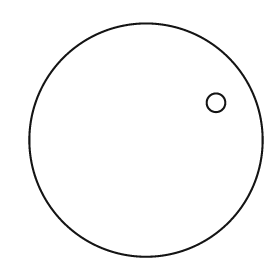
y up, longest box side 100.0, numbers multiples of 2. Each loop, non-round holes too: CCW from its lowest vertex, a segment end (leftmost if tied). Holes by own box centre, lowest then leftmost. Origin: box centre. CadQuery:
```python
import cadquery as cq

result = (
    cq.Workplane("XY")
    .moveTo(0.0, 0.0)
    .circle(50.0)
    .moveTo(30.0, 16.0)
    .circle(4.0)
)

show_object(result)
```